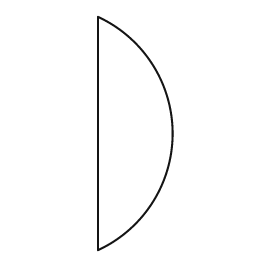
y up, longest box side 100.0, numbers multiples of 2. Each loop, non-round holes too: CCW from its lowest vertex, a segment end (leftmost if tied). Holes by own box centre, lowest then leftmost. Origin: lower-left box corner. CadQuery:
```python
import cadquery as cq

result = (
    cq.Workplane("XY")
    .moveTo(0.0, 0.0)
    .threePointArc((32.0, 50.0), (0.0, 100.0))
    .close()
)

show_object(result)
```